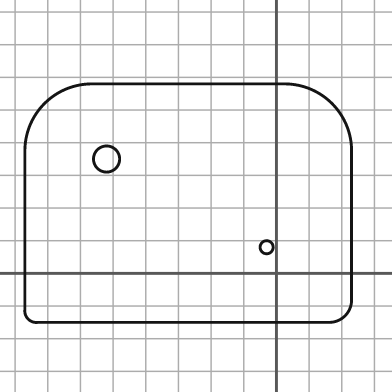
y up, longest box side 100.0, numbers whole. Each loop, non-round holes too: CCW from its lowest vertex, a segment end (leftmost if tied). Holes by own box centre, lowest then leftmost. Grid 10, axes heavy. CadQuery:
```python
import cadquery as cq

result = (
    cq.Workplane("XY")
    .moveTo(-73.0, -15.0)
    .lineTo(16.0, -15.0)
    .threePointArc((21.0, -13.0), (23.0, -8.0))
    .lineTo(23.0, 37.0)
    .threePointArc((17.0, 52.0), (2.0, 58.0))
    .lineTo(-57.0, 58.0)
    .threePointArc((-71.0, 52.0), (-77.0, 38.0))
    .lineTo(-77.0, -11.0)
    .threePointArc((-76.0, -14.0), (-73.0, -15.0))
    .close()
    .moveTo(-3.0, 8.0)
    .circle(2.0)
    .moveTo(-52.0, 35.0)
    .circle(4.0)
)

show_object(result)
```